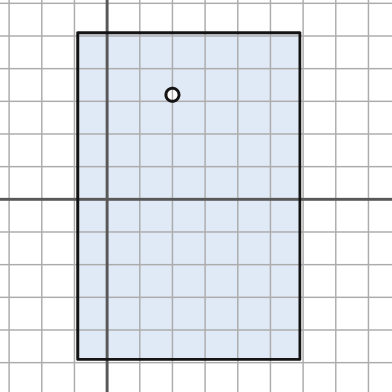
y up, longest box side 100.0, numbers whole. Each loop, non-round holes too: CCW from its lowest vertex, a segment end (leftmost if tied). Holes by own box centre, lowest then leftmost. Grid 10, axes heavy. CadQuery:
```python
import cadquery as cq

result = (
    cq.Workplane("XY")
    .moveTo(-9.0, -49.0)
    .lineTo(59.0, -49.0)
    .lineTo(59.0, 51.0)
    .lineTo(-9.0, 51.0)
    .close()
    .moveTo(20.0, 32.0)
    .circle(2.0)
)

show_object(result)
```